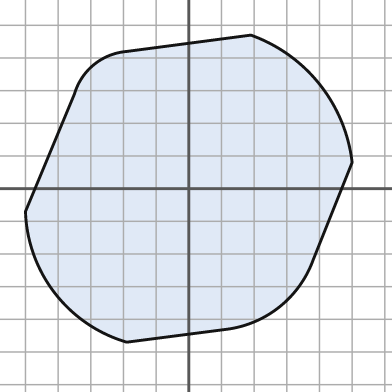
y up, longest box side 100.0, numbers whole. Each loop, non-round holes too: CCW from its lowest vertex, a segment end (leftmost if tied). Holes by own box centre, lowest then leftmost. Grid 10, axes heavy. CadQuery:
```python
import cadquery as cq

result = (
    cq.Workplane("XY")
    .moveTo(-19.0, -47.0)
    .lineTo(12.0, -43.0)
    .threePointArc((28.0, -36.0), (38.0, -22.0))
    .lineTo(50.0, 8.0)
    .threePointArc((40.0, 32.0), (19.0, 47.0))
    .lineTo(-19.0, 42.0)
    .threePointArc((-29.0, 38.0), (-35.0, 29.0))
    .lineTo(-50.0, -7.0)
    .threePointArc((-41.0, -32.0), (-19.0, -47.0))
    .close()
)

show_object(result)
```